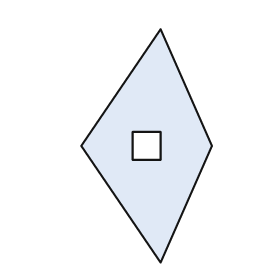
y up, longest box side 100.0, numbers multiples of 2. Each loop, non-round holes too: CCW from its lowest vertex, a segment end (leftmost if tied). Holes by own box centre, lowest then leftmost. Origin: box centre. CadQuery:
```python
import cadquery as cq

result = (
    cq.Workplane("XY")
    .moveTo(6.0, -50.0)
    .lineTo(28.0, 0.0)
    .lineTo(6.0, 50.0)
    .lineTo(-28.0, 0.0)
    .close()
    .moveTo(-6.0, -6.0)
    .lineTo(6.0, -6.0)
    .lineTo(6.0, 6.0)
    .lineTo(-6.0, 6.0)
    .close()
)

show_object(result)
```